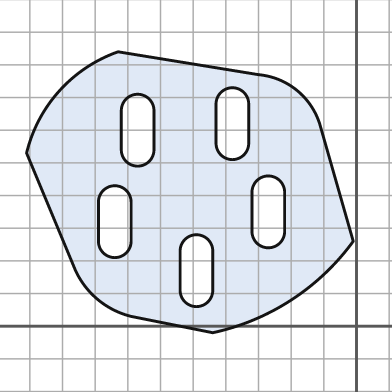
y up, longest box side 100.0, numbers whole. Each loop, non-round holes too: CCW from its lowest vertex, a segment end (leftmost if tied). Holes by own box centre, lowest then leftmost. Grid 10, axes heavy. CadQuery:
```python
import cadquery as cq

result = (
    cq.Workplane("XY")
    .moveTo(-44.0, -2.0)
    .threePointArc((-20.0, 8.0), (-1.0, 26.0))
    .lineTo(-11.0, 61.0)
    .threePointArc((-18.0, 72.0), (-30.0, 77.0))
    .lineTo(-73.0, 84.0)
    .threePointArc((-91.0, 72.0), (-101.0, 53.0))
    .lineTo(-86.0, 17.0)
    .threePointArc((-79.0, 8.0), (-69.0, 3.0))
    .close()
    .moveTo(-54.0, 11.0)
    .threePointArc((-49.0, 6.0), (-44.0, 11.0))
    .lineTo(-44.0, 23.0)
    .threePointArc((-49.0, 28.0), (-54.0, 23.0))
    .close()
    .moveTo(-79.0, 26.0)
    .threePointArc((-74.0, 21.0), (-69.0, 26.0))
    .lineTo(-69.0, 38.0)
    .threePointArc((-74.0, 43.0), (-79.0, 38.0))
    .close()
    .moveTo(-32.0, 29.0)
    .threePointArc((-27.0, 24.0), (-22.0, 29.0))
    .lineTo(-22.0, 41.0)
    .threePointArc((-27.0, 46.0), (-32.0, 41.0))
    .close()
    .moveTo(-72.0, 54.0)
    .threePointArc((-67.0, 49.0), (-62.0, 54.0))
    .lineTo(-62.0, 66.0)
    .threePointArc((-67.0, 71.0), (-72.0, 66.0))
    .close()
    .moveTo(-43.0, 56.0)
    .threePointArc((-38.0, 51.0), (-33.0, 56.0))
    .lineTo(-33.0, 68.0)
    .threePointArc((-38.0, 73.0), (-43.0, 68.0))
    .close()
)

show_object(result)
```